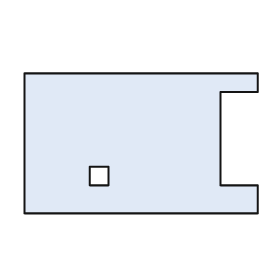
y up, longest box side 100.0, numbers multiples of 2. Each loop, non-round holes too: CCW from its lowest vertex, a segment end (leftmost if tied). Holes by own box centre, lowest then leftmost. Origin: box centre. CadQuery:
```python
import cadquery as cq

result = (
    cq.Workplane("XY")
    .moveTo(-50.0, -30.0)
    .lineTo(50.0, -30.0)
    .lineTo(50.0, -18.0)
    .lineTo(34.0, -18.0)
    .lineTo(34.0, 22.0)
    .lineTo(50.0, 22.0)
    .lineTo(50.0, 30.0)
    .lineTo(-50.0, 30.0)
    .close()
    .moveTo(-22.0, -18.0)
    .lineTo(-14.0, -18.0)
    .lineTo(-14.0, -10.0)
    .lineTo(-22.0, -10.0)
    .close()
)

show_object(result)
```